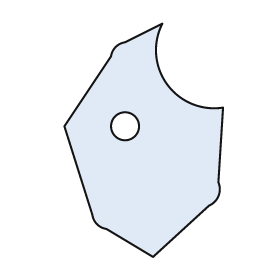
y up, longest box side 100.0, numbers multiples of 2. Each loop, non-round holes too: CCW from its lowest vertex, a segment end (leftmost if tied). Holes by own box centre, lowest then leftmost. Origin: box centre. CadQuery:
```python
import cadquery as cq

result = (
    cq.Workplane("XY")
    .moveTo(4.0, -50.0)
    .lineTo(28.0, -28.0)
    .threePointArc((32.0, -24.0), (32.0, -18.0))
    .lineTo(34.0, 14.0)
    .threePointArc((10.0, 24.0), (8.0, 50.0))
    .lineTo(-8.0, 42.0)
    .threePointArc((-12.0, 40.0), (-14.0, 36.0))
    .lineTo(-34.0, 6.0)
    .lineTo(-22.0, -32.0)
    .threePointArc((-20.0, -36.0), (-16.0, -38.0))
    .close()
    .moveTo(-8.0, 6.0)
    .circle(6.0)
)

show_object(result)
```